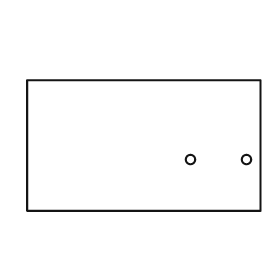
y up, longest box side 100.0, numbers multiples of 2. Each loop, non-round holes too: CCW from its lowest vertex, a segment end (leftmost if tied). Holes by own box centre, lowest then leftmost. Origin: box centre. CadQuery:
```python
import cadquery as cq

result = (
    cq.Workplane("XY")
    .moveTo(-50.0, -28.0)
    .lineTo(50.0, -28.0)
    .lineTo(50.0, 28.0)
    .lineTo(-50.0, 28.0)
    .close()
    .moveTo(20.0, -6.0)
    .circle(2.0)
    .moveTo(44.0, -6.0)
    .circle(2.0)
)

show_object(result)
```